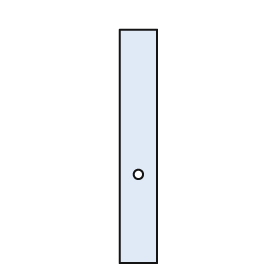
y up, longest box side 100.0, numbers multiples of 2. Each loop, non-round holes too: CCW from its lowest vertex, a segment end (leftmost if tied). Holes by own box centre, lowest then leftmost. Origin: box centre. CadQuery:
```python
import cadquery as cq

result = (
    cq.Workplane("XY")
    .moveTo(-8.0, -50.0)
    .lineTo(8.0, -50.0)
    .lineTo(8.0, 50.0)
    .lineTo(-8.0, 50.0)
    .close()
    .moveTo(0.0, -12.0)
    .circle(2.0)
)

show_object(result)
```